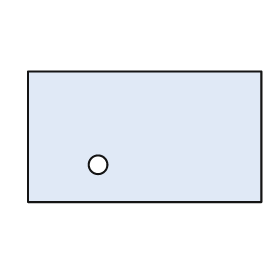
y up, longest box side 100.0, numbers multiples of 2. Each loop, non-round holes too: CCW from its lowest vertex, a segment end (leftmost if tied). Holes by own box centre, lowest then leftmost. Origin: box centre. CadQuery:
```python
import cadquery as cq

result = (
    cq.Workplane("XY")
    .moveTo(-50.0, -28.0)
    .lineTo(50.0, -28.0)
    .lineTo(50.0, 28.0)
    .lineTo(-50.0, 28.0)
    .close()
    .moveTo(-20.0, -12.0)
    .circle(4.0)
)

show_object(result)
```